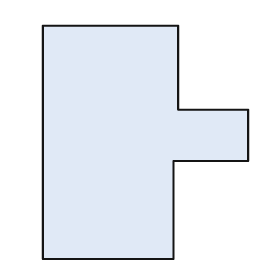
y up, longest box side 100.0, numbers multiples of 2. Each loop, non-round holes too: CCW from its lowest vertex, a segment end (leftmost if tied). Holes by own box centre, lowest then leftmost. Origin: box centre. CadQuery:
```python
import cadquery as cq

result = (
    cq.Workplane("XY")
    .moveTo(-44.0, -50.0)
    .lineTo(12.0, -50.0)
    .lineTo(12.0, -8.0)
    .lineTo(44.0, -8.0)
    .lineTo(44.0, 14.0)
    .lineTo(14.0, 14.0)
    .lineTo(14.0, 50.0)
    .lineTo(-44.0, 50.0)
    .close()
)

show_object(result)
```